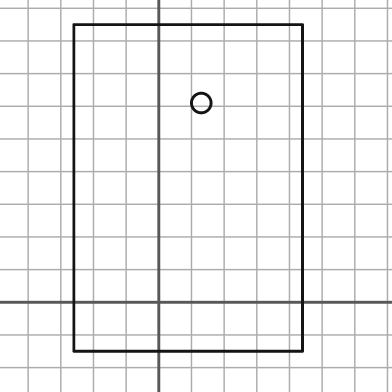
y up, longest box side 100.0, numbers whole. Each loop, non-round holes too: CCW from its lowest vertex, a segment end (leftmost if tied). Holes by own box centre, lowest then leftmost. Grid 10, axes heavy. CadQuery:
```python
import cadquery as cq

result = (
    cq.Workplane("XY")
    .moveTo(-26.0, -15.0)
    .lineTo(44.0, -15.0)
    .lineTo(44.0, 85.0)
    .lineTo(-26.0, 85.0)
    .close()
    .moveTo(13.0, 61.0)
    .circle(3.0)
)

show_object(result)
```